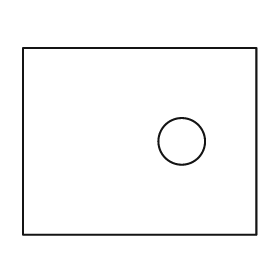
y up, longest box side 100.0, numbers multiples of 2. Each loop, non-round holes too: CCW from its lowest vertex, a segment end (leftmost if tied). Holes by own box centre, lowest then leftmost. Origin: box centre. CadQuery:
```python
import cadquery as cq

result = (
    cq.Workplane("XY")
    .moveTo(-50.0, -40.0)
    .lineTo(50.0, -40.0)
    .lineTo(50.0, 40.0)
    .lineTo(-50.0, 40.0)
    .close()
    .moveTo(18.0, 0.0)
    .circle(10.0)
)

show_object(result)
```